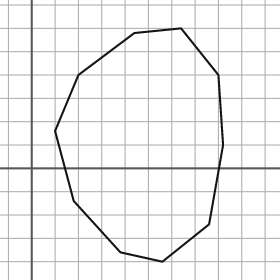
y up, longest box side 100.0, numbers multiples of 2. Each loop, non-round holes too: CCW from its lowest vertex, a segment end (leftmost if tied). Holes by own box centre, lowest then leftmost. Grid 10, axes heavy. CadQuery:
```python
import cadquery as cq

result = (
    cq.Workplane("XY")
    .moveTo(56.0, -40.0)
    .lineTo(76.0, -24.0)
    .lineTo(82.0, 10.0)
    .lineTo(80.0, 40.0)
    .lineTo(64.0, 60.0)
    .lineTo(44.0, 58.0)
    .lineTo(20.0, 40.0)
    .lineTo(10.0, 16.0)
    .lineTo(18.0, -14.0)
    .lineTo(38.0, -36.0)
    .close()
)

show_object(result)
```